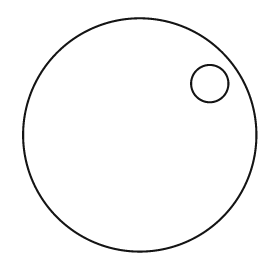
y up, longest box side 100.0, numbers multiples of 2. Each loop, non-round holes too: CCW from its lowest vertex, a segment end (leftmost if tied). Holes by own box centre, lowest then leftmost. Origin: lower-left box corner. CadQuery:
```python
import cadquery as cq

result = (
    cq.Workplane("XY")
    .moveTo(50.0, 50.0)
    .circle(50.0)
    .moveTo(80.0, 72.0)
    .circle(8.0)
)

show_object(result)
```